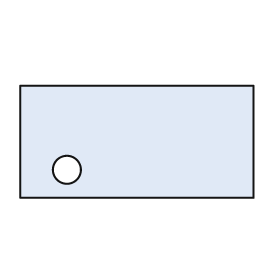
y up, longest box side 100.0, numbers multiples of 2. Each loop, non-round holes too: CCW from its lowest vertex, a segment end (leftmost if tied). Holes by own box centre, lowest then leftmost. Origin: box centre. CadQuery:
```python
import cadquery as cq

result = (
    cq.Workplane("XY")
    .moveTo(-50.0, -24.0)
    .lineTo(50.0, -24.0)
    .lineTo(50.0, 24.0)
    .lineTo(-50.0, 24.0)
    .close()
    .moveTo(-30.0, -12.0)
    .circle(6.0)
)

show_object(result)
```